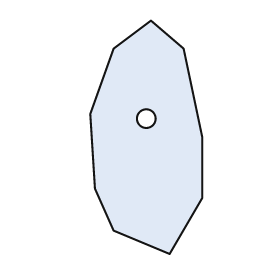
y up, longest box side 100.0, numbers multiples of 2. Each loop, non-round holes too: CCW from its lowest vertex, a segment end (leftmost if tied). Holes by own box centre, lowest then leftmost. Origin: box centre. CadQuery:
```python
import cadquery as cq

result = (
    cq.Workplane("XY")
    .moveTo(10.0, -50.0)
    .lineTo(24.0, -26.0)
    .lineTo(24.0, 0.0)
    .lineTo(16.0, 38.0)
    .lineTo(2.0, 50.0)
    .lineTo(-14.0, 38.0)
    .lineTo(-24.0, 10.0)
    .lineTo(-22.0, -22.0)
    .lineTo(-14.0, -40.0)
    .close()
    .moveTo(0.0, 8.0)
    .circle(4.0)
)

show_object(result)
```